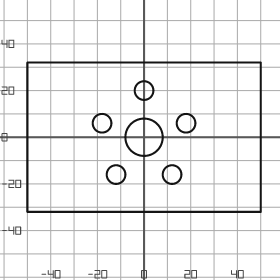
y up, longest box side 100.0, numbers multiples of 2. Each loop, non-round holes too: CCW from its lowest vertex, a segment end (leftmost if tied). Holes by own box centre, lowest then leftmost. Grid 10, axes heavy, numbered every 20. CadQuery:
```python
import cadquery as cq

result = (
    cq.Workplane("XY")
    .moveTo(-50.0, -32.0)
    .lineTo(50.0, -32.0)
    .lineTo(50.0, 32.0)
    .lineTo(-50.0, 32.0)
    .close()
    .moveTo(-12.0, -16.0)
    .circle(4.0)
    .moveTo(12.0, -16.0)
    .circle(4.0)
    .moveTo(0.0, 0.0)
    .circle(8.0)
    .moveTo(-18.0, 6.0)
    .circle(4.0)
    .moveTo(18.0, 6.0)
    .circle(4.0)
    .moveTo(0.0, 20.0)
    .circle(4.0)
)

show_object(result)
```